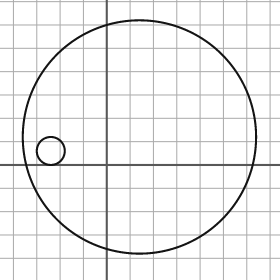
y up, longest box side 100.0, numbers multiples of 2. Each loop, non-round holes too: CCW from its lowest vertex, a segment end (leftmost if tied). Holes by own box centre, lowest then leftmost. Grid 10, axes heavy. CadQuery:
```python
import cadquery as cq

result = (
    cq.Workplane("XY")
    .moveTo(14.0, 12.0)
    .circle(50.0)
    .moveTo(-24.0, 6.0)
    .circle(6.0)
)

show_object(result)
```